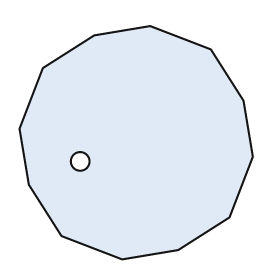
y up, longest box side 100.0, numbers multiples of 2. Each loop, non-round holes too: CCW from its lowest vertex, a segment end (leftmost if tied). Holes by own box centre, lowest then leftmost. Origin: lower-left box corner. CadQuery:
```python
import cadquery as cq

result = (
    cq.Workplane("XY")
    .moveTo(44.0, 0.0)
    .lineTo(68.0, 4.0)
    .lineTo(90.0, 18.0)
    .lineTo(100.0, 44.0)
    .lineTo(96.0, 68.0)
    .lineTo(82.0, 90.0)
    .lineTo(56.0, 100.0)
    .lineTo(32.0, 96.0)
    .lineTo(10.0, 82.0)
    .lineTo(0.0, 56.0)
    .lineTo(4.0, 32.0)
    .lineTo(18.0, 10.0)
    .close()
    .moveTo(26.0, 42.0)
    .circle(4.0)
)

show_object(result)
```